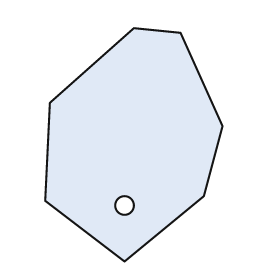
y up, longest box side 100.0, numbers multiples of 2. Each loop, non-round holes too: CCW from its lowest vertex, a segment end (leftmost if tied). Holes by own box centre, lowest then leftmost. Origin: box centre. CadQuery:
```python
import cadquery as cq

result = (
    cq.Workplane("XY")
    .moveTo(-4.0, -50.0)
    .lineTo(30.0, -22.0)
    .lineTo(38.0, 8.0)
    .lineTo(20.0, 48.0)
    .lineTo(0.0, 50.0)
    .lineTo(-36.0, 18.0)
    .lineTo(-38.0, -24.0)
    .close()
    .moveTo(-4.0, -26.0)
    .circle(4.0)
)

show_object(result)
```